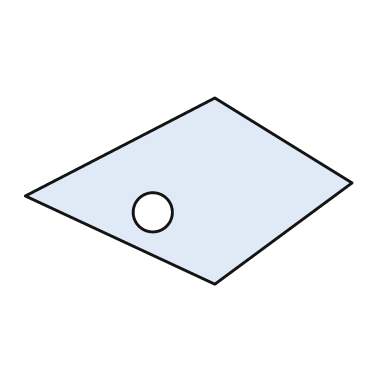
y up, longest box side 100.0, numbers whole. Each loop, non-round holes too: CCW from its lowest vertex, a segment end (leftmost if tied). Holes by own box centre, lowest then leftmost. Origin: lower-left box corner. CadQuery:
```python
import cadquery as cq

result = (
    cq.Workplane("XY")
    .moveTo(58.0, 0.0)
    .lineTo(100.0, 31.0)
    .lineTo(58.0, 57.0)
    .lineTo(0.0, 27.0)
    .close()
    .moveTo(39.0, 22.0)
    .circle(6.0)
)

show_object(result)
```